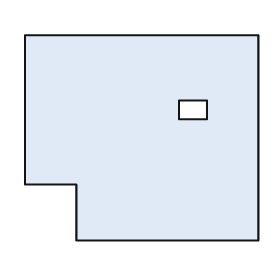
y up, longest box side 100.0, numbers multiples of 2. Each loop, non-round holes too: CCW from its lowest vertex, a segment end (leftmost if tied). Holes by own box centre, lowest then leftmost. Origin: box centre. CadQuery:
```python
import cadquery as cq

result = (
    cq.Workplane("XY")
    .moveTo(-28.0, -44.0)
    .lineTo(50.0, -44.0)
    .lineTo(50.0, 44.0)
    .lineTo(-50.0, 44.0)
    .lineTo(-50.0, -20.0)
    .lineTo(-28.0, -20.0)
    .close()
    .moveTo(16.0, 8.0)
    .lineTo(28.0, 8.0)
    .lineTo(28.0, 16.0)
    .lineTo(16.0, 16.0)
    .close()
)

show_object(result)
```